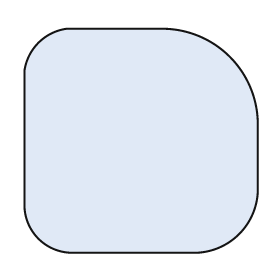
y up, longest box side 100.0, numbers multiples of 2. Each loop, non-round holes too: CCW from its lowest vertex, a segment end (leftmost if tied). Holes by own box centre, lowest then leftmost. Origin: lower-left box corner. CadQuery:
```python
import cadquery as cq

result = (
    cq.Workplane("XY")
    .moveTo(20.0, 0.0)
    .lineTo(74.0, 0.0)
    .threePointArc((92.0, 8.0), (100.0, 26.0))
    .lineTo(100.0, 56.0)
    .threePointArc((88.0, 84.0), (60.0, 96.0))
    .lineTo(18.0, 96.0)
    .threePointArc((6.0, 90.0), (0.0, 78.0))
    .lineTo(0.0, 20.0)
    .threePointArc((6.0, 6.0), (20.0, 0.0))
    .close()
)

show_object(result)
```